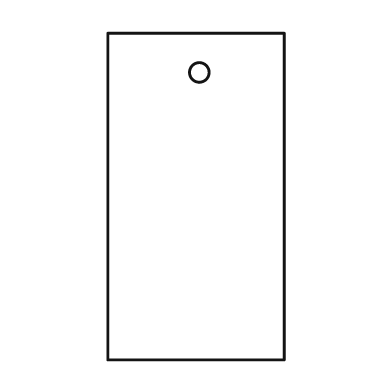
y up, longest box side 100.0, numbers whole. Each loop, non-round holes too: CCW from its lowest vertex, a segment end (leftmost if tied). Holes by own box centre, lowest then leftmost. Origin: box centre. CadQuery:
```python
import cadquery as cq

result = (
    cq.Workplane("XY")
    .moveTo(-27.0, -50.0)
    .lineTo(27.0, -50.0)
    .lineTo(27.0, 50.0)
    .lineTo(-27.0, 50.0)
    .close()
    .moveTo(1.0, 38.0)
    .circle(3.0)
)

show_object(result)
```